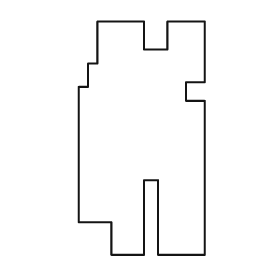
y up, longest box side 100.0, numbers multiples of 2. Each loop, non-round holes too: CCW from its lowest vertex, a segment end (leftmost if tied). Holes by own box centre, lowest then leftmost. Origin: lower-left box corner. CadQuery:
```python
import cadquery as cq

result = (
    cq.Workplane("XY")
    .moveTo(14.0, 0.0)
    .lineTo(28.0, 0.0)
    .lineTo(28.0, 32.0)
    .lineTo(34.0, 32.0)
    .lineTo(34.0, 0.0)
    .lineTo(54.0, 0.0)
    .lineTo(54.0, 66.0)
    .lineTo(46.0, 66.0)
    .lineTo(46.0, 74.0)
    .lineTo(54.0, 74.0)
    .lineTo(54.0, 100.0)
    .lineTo(38.0, 100.0)
    .lineTo(38.0, 88.0)
    .lineTo(28.0, 88.0)
    .lineTo(28.0, 100.0)
    .lineTo(8.0, 100.0)
    .lineTo(8.0, 82.0)
    .lineTo(4.0, 82.0)
    .lineTo(4.0, 72.0)
    .lineTo(0.0, 72.0)
    .lineTo(0.0, 14.0)
    .lineTo(14.0, 14.0)
    .close()
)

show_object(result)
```